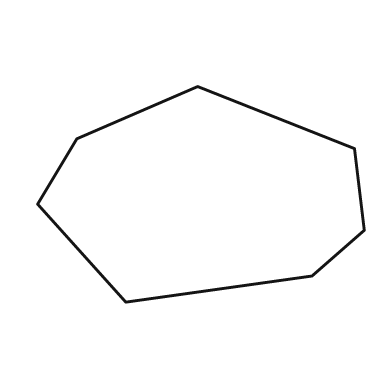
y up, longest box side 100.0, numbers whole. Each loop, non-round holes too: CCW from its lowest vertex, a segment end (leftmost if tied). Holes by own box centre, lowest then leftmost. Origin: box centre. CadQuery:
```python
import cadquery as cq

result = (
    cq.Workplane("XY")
    .moveTo(-23.0, -33.0)
    .lineTo(34.0, -25.0)
    .lineTo(50.0, -11.0)
    .lineTo(47.0, 14.0)
    .lineTo(-1.0, 33.0)
    .lineTo(-38.0, 17.0)
    .lineTo(-50.0, -3.0)
    .close()
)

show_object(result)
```